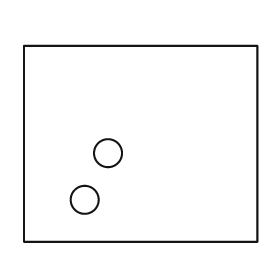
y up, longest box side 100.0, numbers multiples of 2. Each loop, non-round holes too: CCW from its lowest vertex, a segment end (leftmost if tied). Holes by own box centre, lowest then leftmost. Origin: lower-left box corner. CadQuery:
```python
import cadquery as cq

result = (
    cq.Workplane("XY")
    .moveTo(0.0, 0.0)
    .lineTo(100.0, 0.0)
    .lineTo(100.0, 84.0)
    .lineTo(0.0, 84.0)
    .close()
    .moveTo(26.0, 18.0)
    .circle(6.0)
    .moveTo(36.0, 38.0)
    .circle(6.0)
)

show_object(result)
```